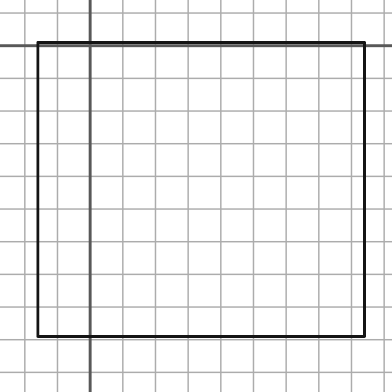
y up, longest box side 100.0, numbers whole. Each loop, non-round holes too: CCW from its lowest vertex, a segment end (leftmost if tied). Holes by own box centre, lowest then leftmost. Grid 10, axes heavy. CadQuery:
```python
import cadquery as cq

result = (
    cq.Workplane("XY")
    .moveTo(-16.0, -89.0)
    .lineTo(84.0, -89.0)
    .lineTo(84.0, 1.0)
    .lineTo(-16.0, 1.0)
    .close()
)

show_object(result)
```